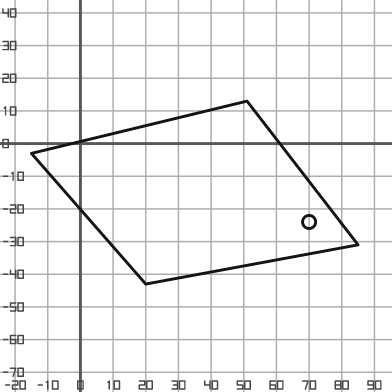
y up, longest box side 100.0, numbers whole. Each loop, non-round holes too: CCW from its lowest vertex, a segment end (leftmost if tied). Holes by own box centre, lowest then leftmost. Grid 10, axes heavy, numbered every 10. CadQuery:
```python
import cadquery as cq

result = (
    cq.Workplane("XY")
    .moveTo(20.0, -43.0)
    .lineTo(85.0, -31.0)
    .lineTo(51.0, 13.0)
    .lineTo(-15.0, -3.0)
    .close()
    .moveTo(70.0, -24.0)
    .circle(2.0)
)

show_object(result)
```